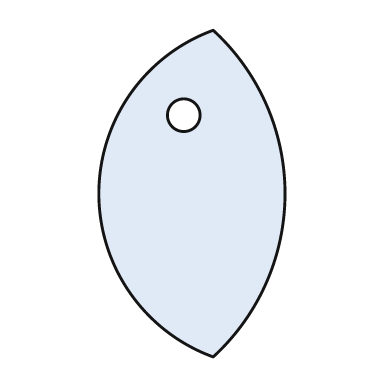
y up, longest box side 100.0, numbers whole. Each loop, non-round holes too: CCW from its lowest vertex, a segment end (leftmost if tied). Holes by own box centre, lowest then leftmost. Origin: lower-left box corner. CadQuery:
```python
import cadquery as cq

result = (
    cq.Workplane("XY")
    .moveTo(35.0, 0.0)
    .threePointArc((57.0, 50.0), (35.0, 100.0))
    .threePointArc((0.0, 50.0), (35.0, 0.0))
    .close()
    .moveTo(26.0, 74.0)
    .circle(5.0)
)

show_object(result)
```